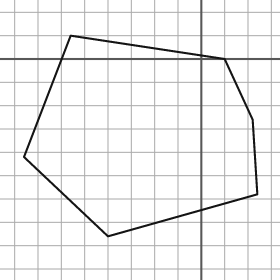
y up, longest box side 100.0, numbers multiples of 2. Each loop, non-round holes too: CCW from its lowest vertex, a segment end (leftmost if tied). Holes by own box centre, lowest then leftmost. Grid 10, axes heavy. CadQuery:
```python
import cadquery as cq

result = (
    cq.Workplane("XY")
    .moveTo(-40.0, -76.0)
    .lineTo(24.0, -58.0)
    .lineTo(22.0, -26.0)
    .lineTo(10.0, 0.0)
    .lineTo(-56.0, 10.0)
    .lineTo(-76.0, -42.0)
    .close()
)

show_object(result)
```